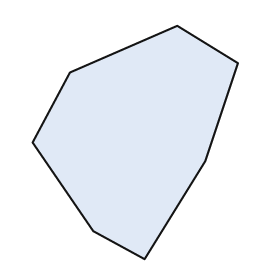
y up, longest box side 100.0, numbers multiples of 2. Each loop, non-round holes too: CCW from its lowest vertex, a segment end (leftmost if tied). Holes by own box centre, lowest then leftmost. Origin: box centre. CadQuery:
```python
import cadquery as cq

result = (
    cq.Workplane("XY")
    .moveTo(4.0, -50.0)
    .lineTo(30.0, -8.0)
    .lineTo(44.0, 34.0)
    .lineTo(18.0, 50.0)
    .lineTo(-28.0, 30.0)
    .lineTo(-44.0, 0.0)
    .lineTo(-18.0, -38.0)
    .close()
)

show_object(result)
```